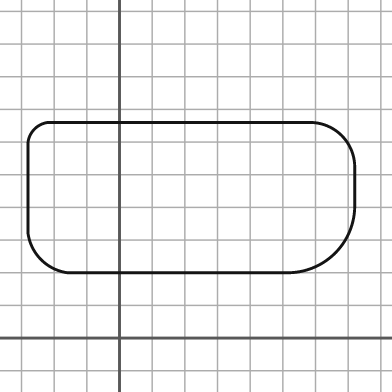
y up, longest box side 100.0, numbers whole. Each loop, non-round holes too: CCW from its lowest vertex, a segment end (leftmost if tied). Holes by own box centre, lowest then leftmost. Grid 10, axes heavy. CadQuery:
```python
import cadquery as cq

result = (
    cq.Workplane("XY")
    .moveTo(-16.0, 20.0)
    .lineTo(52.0, 20.0)
    .threePointArc((66.0, 26.0), (72.0, 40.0))
    .lineTo(72.0, 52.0)
    .threePointArc((68.0, 62.0), (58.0, 66.0))
    .lineTo(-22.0, 66.0)
    .threePointArc((-26.0, 64.0), (-28.0, 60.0))
    .lineTo(-28.0, 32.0)
    .threePointArc((-24.0, 24.0), (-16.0, 20.0))
    .close()
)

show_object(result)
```